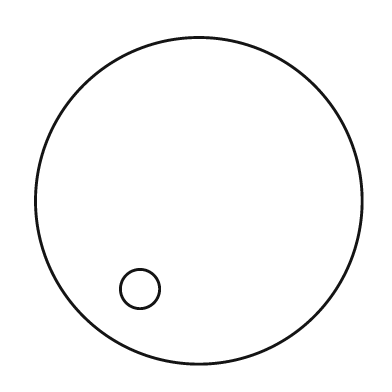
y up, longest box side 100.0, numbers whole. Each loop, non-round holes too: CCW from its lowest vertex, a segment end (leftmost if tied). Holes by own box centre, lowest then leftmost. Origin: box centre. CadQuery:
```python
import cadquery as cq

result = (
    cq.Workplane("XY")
    .moveTo(0.0, 0.0)
    .circle(50.0)
    .moveTo(-18.0, -27.0)
    .circle(6.0)
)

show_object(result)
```